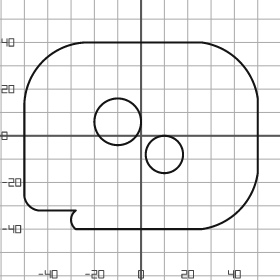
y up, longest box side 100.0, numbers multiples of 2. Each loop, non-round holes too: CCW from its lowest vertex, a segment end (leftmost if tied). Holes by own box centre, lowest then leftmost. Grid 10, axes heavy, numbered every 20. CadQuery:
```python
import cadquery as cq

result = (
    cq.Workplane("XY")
    .moveTo(-28.0, -40.0)
    .lineTo(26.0, -40.0)
    .threePointArc((42.0, -32.0), (50.0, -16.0))
    .lineTo(50.0, 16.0)
    .threePointArc((42.0, 32.0), (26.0, 40.0))
    .lineTo(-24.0, 40.0)
    .threePointArc((-42.0, 32.0), (-50.0, 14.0))
    .lineTo(-50.0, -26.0)
    .threePointArc((-48.0, -30.0), (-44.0, -32.0))
    .lineTo(-28.0, -32.0)
    .threePointArc((-30.0, -36.0), (-28.0, -40.0))
    .close()
    .moveTo(10.0, -8.0)
    .circle(8.0)
    .moveTo(-10.0, 6.0)
    .circle(10.0)
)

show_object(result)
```